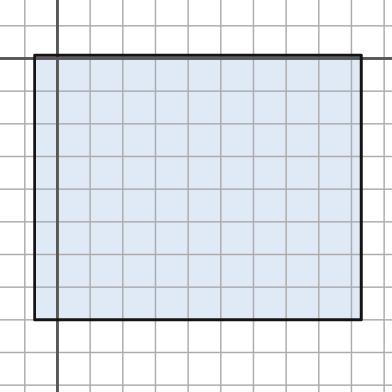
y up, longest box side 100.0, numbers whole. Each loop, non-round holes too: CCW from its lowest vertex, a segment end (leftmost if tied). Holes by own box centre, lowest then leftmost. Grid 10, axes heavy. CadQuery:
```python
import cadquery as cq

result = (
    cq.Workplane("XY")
    .moveTo(-7.0, -80.0)
    .lineTo(93.0, -80.0)
    .lineTo(93.0, 1.0)
    .lineTo(-7.0, 1.0)
    .close()
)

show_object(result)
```